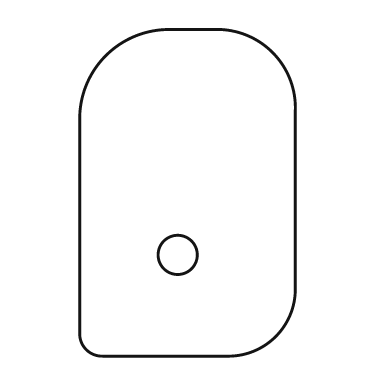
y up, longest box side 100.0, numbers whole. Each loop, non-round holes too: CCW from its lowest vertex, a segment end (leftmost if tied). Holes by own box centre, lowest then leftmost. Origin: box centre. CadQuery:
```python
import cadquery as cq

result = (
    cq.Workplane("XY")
    .moveTo(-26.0, -50.0)
    .lineTo(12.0, -50.0)
    .threePointArc((27.0, -44.0), (33.0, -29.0))
    .lineTo(33.0, 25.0)
    .threePointArc((26.0, 43.0), (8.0, 50.0))
    .lineTo(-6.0, 50.0)
    .threePointArc((-25.0, 42.0), (-33.0, 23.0))
    .lineTo(-33.0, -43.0)
    .threePointArc((-31.0, -48.0), (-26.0, -50.0))
    .close()
    .moveTo(-3.0, -19.0)
    .circle(6.0)
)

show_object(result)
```